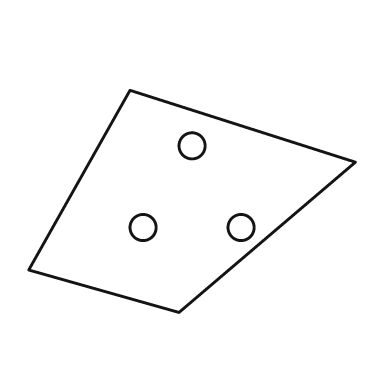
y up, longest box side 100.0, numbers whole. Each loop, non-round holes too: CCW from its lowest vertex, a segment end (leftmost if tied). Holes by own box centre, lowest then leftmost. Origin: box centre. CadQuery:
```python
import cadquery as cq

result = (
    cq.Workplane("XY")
    .moveTo(-4.0, -34.0)
    .lineTo(50.0, 12.0)
    .lineTo(-19.0, 34.0)
    .lineTo(-50.0, -21.0)
    .close()
    .moveTo(-15.0, -8.0)
    .circle(4.0)
    .moveTo(15.0, -8.0)
    .circle(4.0)
    .moveTo(0.0, 17.0)
    .circle(4.0)
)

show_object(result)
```